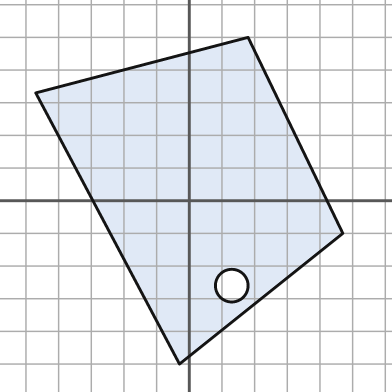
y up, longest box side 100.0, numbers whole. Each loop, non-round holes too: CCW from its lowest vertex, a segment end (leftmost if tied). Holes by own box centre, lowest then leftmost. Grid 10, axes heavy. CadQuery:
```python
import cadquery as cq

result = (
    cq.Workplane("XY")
    .moveTo(-3.0, -50.0)
    .lineTo(47.0, -10.0)
    .lineTo(18.0, 50.0)
    .lineTo(-47.0, 33.0)
    .close()
    .moveTo(13.0, -26.0)
    .circle(5.0)
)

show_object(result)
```